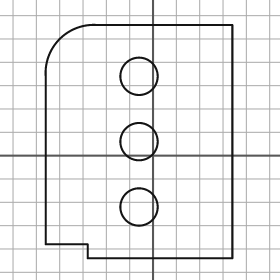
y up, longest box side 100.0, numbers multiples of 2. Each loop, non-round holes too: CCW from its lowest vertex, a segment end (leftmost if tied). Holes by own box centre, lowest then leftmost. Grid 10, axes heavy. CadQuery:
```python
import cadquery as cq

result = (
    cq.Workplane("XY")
    .moveTo(-28.0, -44.0)
    .lineTo(34.0, -44.0)
    .lineTo(34.0, 56.0)
    .lineTo(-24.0, 56.0)
    .threePointArc((-40.0, 50.0), (-46.0, 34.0))
    .lineTo(-46.0, -38.0)
    .lineTo(-28.0, -38.0)
    .close()
    .moveTo(-6.0, -22.0)
    .circle(8.0)
    .moveTo(-6.0, 6.0)
    .circle(8.0)
    .moveTo(-6.0, 34.0)
    .circle(8.0)
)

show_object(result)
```